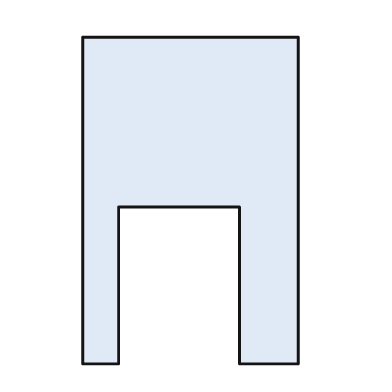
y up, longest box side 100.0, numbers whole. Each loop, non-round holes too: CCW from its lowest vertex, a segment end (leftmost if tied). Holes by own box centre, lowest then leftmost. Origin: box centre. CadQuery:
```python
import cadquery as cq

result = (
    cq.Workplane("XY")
    .moveTo(-33.0, -50.0)
    .lineTo(-22.0, -50.0)
    .lineTo(-22.0, -2.0)
    .lineTo(15.0, -2.0)
    .lineTo(15.0, -50.0)
    .lineTo(33.0, -50.0)
    .lineTo(33.0, 50.0)
    .lineTo(-33.0, 50.0)
    .close()
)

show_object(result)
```